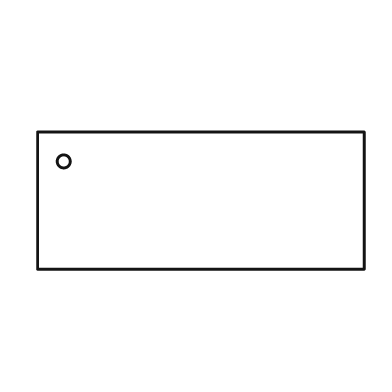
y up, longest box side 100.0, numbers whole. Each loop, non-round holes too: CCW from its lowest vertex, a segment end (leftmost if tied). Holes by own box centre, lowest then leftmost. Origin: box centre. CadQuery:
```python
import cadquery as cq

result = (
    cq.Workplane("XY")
    .moveTo(-50.0, -21.0)
    .lineTo(50.0, -21.0)
    .lineTo(50.0, 21.0)
    .lineTo(-50.0, 21.0)
    .close()
    .moveTo(-42.0, 12.0)
    .circle(2.0)
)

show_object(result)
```